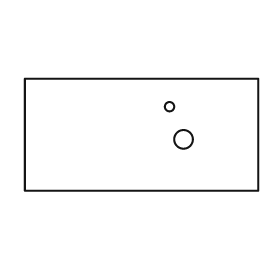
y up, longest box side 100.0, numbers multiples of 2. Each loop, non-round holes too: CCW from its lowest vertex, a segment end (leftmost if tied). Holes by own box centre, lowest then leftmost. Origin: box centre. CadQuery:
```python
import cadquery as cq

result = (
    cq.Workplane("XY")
    .moveTo(-50.0, -24.0)
    .lineTo(50.0, -24.0)
    .lineTo(50.0, 24.0)
    .lineTo(-50.0, 24.0)
    .close()
    .moveTo(18.0, -2.0)
    .circle(4.0)
    .moveTo(12.0, 12.0)
    .circle(2.0)
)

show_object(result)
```